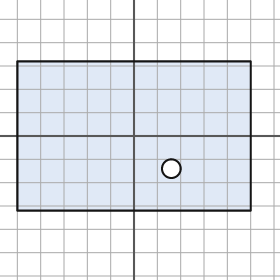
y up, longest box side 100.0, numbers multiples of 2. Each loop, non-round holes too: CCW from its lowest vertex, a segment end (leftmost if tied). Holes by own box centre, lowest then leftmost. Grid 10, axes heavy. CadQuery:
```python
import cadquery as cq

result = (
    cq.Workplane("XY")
    .moveTo(-50.0, -32.0)
    .lineTo(50.0, -32.0)
    .lineTo(50.0, 32.0)
    .lineTo(-50.0, 32.0)
    .close()
    .moveTo(16.0, -14.0)
    .circle(4.0)
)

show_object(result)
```